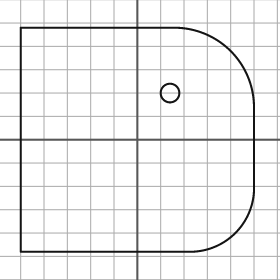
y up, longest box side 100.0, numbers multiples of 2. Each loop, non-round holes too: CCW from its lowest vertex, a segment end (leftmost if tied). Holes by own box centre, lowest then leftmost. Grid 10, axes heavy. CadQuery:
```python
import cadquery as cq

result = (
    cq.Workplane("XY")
    .moveTo(-50.0, -48.0)
    .lineTo(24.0, -48.0)
    .threePointArc((42.0, -40.0), (50.0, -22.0))
    .lineTo(50.0, 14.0)
    .threePointArc((40.0, 38.0), (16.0, 48.0))
    .lineTo(-50.0, 48.0)
    .close()
    .moveTo(14.0, 20.0)
    .circle(4.0)
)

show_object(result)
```